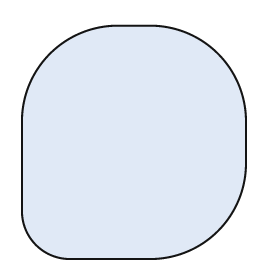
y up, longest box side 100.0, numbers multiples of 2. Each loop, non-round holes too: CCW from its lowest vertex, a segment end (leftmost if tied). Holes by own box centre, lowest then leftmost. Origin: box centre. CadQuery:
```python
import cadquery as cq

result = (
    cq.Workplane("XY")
    .moveTo(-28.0, -50.0)
    .lineTo(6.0, -50.0)
    .threePointArc((36.0, -38.0), (48.0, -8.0))
    .lineTo(48.0, 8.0)
    .threePointArc((36.0, 38.0), (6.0, 50.0))
    .lineTo(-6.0, 50.0)
    .threePointArc((-36.0, 38.0), (-48.0, 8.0))
    .lineTo(-48.0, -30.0)
    .threePointArc((-42.0, -44.0), (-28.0, -50.0))
    .close()
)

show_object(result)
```